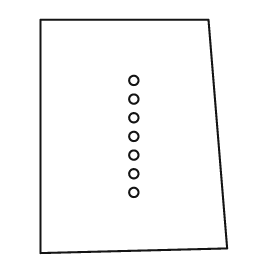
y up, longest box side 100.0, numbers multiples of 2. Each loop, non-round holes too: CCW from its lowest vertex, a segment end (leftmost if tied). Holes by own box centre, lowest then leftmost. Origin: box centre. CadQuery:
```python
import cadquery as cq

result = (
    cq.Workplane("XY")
    .moveTo(-40.0, -50.0)
    .lineTo(40.0, -48.0)
    .lineTo(32.0, 50.0)
    .lineTo(-40.0, 50.0)
    .close()
    .moveTo(0.0, -24.0)
    .circle(2.0)
    .moveTo(0.0, -16.0)
    .circle(2.0)
    .moveTo(0.0, -8.0)
    .circle(2.0)
    .moveTo(0.0, 0.0)
    .circle(2.0)
    .moveTo(0.0, 8.0)
    .circle(2.0)
    .moveTo(0.0, 16.0)
    .circle(2.0)
    .moveTo(0.0, 24.0)
    .circle(2.0)
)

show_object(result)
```